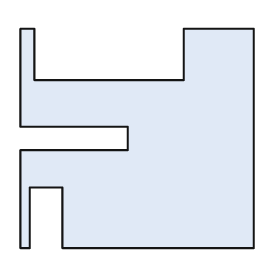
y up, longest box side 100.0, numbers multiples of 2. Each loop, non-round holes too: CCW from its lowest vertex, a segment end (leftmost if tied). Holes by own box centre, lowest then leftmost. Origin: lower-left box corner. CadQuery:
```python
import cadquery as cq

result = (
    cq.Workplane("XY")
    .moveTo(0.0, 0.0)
    .lineTo(4.0, 0.0)
    .lineTo(4.0, 26.0)
    .lineTo(18.0, 26.0)
    .lineTo(18.0, 0.0)
    .lineTo(100.0, 0.0)
    .lineTo(100.0, 94.0)
    .lineTo(70.0, 94.0)
    .lineTo(70.0, 72.0)
    .lineTo(6.0, 72.0)
    .lineTo(6.0, 94.0)
    .lineTo(0.0, 94.0)
    .lineTo(0.0, 52.0)
    .lineTo(46.0, 52.0)
    .lineTo(46.0, 42.0)
    .lineTo(0.0, 42.0)
    .close()
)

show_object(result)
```